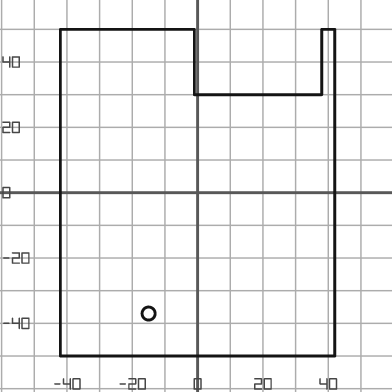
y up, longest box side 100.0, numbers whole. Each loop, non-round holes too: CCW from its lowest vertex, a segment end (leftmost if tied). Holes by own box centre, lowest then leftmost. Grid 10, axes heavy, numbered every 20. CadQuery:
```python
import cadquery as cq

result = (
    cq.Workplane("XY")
    .moveTo(-42.0, -50.0)
    .lineTo(42.0, -50.0)
    .lineTo(42.0, 50.0)
    .lineTo(38.0, 50.0)
    .lineTo(38.0, 30.0)
    .lineTo(-1.0, 30.0)
    .lineTo(-1.0, 50.0)
    .lineTo(-42.0, 50.0)
    .close()
    .moveTo(-15.0, -37.0)
    .circle(2.0)
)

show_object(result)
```